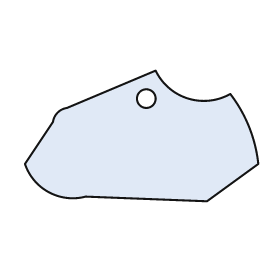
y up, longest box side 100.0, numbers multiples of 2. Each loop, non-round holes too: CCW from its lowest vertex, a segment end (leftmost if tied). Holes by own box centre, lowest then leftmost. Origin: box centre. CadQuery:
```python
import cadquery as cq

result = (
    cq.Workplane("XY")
    .moveTo(28.0, -28.0)
    .lineTo(50.0, -12.0)
    .threePointArc((46.0, 4.0), (38.0, 18.0))
    .threePointArc((20.0, 16.0), (6.0, 28.0))
    .lineTo(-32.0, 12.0)
    .threePointArc((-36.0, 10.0), (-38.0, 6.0))
    .lineTo(-50.0, -12.0)
    .threePointArc((-40.0, -24.0), (-24.0, -26.0))
    .close()
    .moveTo(2.0, 16.0)
    .circle(4.0)
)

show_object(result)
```